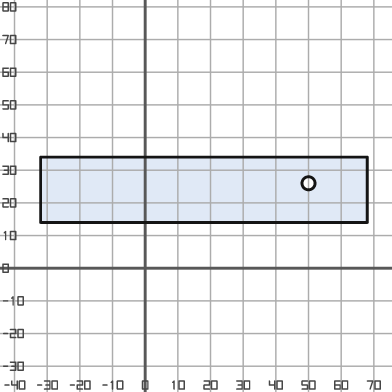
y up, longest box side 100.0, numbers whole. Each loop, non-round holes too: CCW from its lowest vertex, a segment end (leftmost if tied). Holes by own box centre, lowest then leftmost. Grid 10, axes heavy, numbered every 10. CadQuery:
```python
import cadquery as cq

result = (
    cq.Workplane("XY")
    .moveTo(-32.0, 14.0)
    .lineTo(68.0, 14.0)
    .lineTo(68.0, 34.0)
    .lineTo(-32.0, 34.0)
    .close()
    .moveTo(50.0, 26.0)
    .circle(2.0)
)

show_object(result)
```